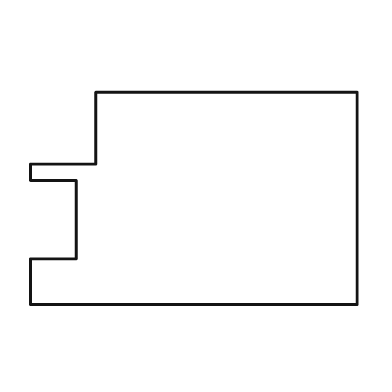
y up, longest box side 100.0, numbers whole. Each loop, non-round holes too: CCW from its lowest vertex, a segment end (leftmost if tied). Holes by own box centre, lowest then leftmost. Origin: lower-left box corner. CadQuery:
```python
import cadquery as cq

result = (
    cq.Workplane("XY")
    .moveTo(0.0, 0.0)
    .lineTo(100.0, 0.0)
    .lineTo(100.0, 65.0)
    .lineTo(20.0, 65.0)
    .lineTo(20.0, 43.0)
    .lineTo(0.0, 43.0)
    .lineTo(0.0, 38.0)
    .lineTo(14.0, 38.0)
    .lineTo(14.0, 14.0)
    .lineTo(0.0, 14.0)
    .close()
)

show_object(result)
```